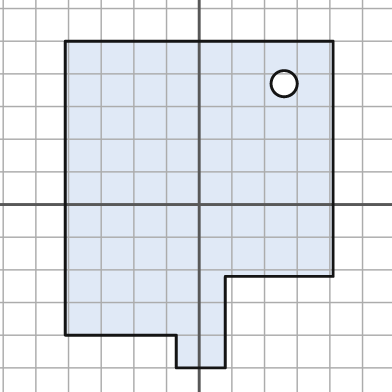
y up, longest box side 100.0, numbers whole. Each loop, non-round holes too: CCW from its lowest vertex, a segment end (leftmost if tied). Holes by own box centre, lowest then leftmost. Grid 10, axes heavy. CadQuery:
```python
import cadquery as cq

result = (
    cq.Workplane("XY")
    .moveTo(-7.0, -50.0)
    .lineTo(8.0, -50.0)
    .lineTo(8.0, -22.0)
    .lineTo(41.0, -22.0)
    .lineTo(41.0, 50.0)
    .lineTo(-41.0, 50.0)
    .lineTo(-41.0, -40.0)
    .lineTo(-7.0, -40.0)
    .close()
    .moveTo(26.0, 37.0)
    .circle(4.0)
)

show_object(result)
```